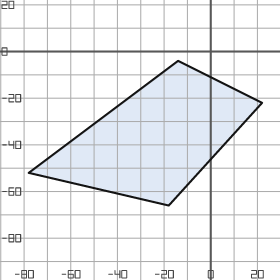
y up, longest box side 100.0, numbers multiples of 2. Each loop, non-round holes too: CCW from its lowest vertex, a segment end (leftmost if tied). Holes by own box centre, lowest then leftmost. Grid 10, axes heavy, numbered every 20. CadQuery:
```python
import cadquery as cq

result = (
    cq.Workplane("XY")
    .moveTo(-18.0, -66.0)
    .lineTo(22.0, -22.0)
    .lineTo(-14.0, -4.0)
    .lineTo(-78.0, -52.0)
    .close()
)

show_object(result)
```